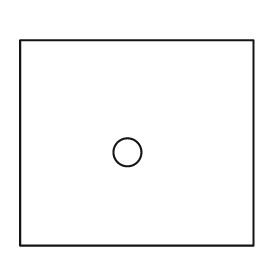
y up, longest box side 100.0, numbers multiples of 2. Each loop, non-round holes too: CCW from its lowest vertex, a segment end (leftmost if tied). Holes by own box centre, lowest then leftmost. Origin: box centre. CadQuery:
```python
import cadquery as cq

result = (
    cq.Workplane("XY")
    .moveTo(-50.0, -44.0)
    .lineTo(50.0, -44.0)
    .lineTo(50.0, 44.0)
    .lineTo(-50.0, 44.0)
    .close()
    .moveTo(-4.0, -4.0)
    .circle(6.0)
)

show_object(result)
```